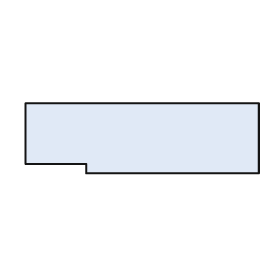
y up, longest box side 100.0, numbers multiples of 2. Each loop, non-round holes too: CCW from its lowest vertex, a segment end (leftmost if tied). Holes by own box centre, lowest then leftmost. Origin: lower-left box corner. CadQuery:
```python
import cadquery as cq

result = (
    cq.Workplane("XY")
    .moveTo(26.0, 0.0)
    .lineTo(100.0, 0.0)
    .lineTo(100.0, 30.0)
    .lineTo(0.0, 30.0)
    .lineTo(0.0, 4.0)
    .lineTo(26.0, 4.0)
    .close()
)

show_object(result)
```